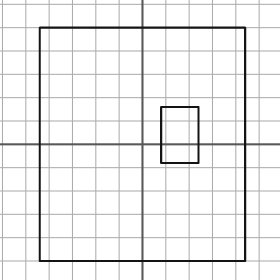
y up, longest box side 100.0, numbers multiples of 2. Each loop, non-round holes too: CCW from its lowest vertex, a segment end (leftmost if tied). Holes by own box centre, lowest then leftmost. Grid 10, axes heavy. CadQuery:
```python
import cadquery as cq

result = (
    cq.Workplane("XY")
    .moveTo(-44.0, -50.0)
    .lineTo(44.0, -50.0)
    .lineTo(44.0, 50.0)
    .lineTo(-44.0, 50.0)
    .close()
    .moveTo(8.0, -8.0)
    .lineTo(24.0, -8.0)
    .lineTo(24.0, 16.0)
    .lineTo(8.0, 16.0)
    .close()
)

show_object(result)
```